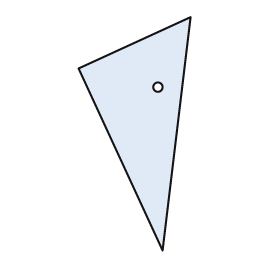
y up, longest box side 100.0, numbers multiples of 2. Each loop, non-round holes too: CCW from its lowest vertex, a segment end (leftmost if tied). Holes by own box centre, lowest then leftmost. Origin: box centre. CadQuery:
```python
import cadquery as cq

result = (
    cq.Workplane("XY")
    .moveTo(12.0, -50.0)
    .lineTo(24.0, 50.0)
    .lineTo(-24.0, 28.0)
    .close()
    .moveTo(10.0, 20.0)
    .circle(2.0)
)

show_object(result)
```